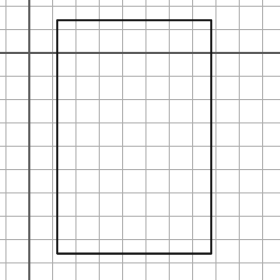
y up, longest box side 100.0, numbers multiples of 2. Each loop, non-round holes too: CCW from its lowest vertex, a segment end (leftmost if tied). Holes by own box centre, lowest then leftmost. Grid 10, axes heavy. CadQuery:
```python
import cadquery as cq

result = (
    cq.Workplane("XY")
    .moveTo(12.0, -86.0)
    .lineTo(78.0, -86.0)
    .lineTo(78.0, 14.0)
    .lineTo(12.0, 14.0)
    .close()
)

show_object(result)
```